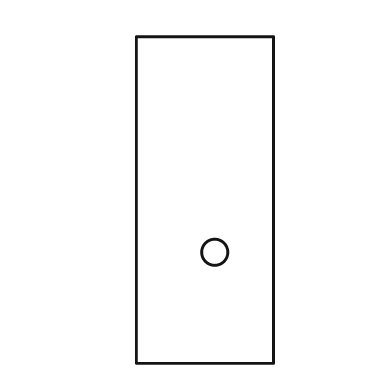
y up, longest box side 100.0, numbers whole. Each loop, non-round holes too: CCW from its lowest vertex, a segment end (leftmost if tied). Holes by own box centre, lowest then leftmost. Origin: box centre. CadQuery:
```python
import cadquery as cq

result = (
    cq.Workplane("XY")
    .moveTo(-21.0, -50.0)
    .lineTo(21.0, -50.0)
    .lineTo(21.0, 50.0)
    .lineTo(-21.0, 50.0)
    .close()
    .moveTo(3.0, -16.0)
    .circle(4.0)
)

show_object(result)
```